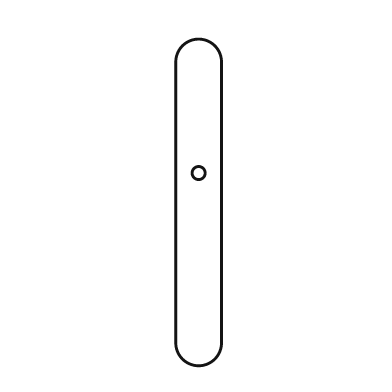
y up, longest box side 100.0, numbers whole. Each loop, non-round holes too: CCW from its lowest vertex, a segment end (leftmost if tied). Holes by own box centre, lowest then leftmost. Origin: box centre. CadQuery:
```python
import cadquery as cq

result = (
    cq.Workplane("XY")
    .moveTo(-7.0, -43.0)
    .threePointArc((0.0, -50.0), (7.0, -43.0))
    .lineTo(7.0, 43.0)
    .threePointArc((0.0, 50.0), (-7.0, 43.0))
    .close()
    .moveTo(0.0, 9.0)
    .circle(2.0)
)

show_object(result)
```